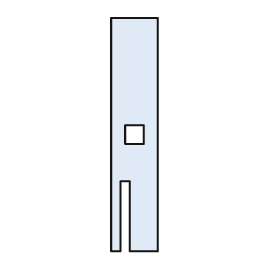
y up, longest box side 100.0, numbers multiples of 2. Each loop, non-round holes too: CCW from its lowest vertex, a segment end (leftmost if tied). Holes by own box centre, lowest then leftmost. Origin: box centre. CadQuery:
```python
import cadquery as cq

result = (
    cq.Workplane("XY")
    .moveTo(-10.0, -50.0)
    .lineTo(-6.0, -50.0)
    .lineTo(-6.0, -20.0)
    .lineTo(-2.0, -20.0)
    .lineTo(-2.0, -50.0)
    .lineTo(10.0, -50.0)
    .lineTo(10.0, 50.0)
    .lineTo(-10.0, 50.0)
    .close()
    .moveTo(-4.0, -4.0)
    .lineTo(4.0, -4.0)
    .lineTo(4.0, 4.0)
    .lineTo(-4.0, 4.0)
    .close()
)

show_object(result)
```